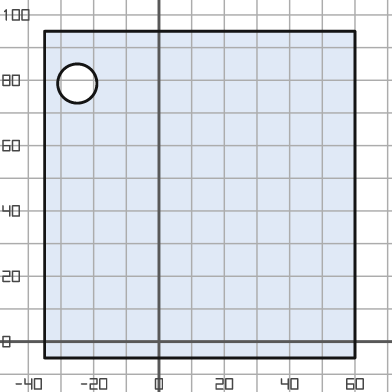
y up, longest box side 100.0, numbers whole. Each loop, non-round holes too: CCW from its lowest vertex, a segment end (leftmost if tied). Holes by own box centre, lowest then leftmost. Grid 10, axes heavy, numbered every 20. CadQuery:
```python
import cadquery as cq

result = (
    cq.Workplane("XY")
    .moveTo(-35.0, -5.0)
    .lineTo(60.0, -5.0)
    .lineTo(60.0, 95.0)
    .lineTo(-35.0, 95.0)
    .close()
    .moveTo(-25.0, 79.0)
    .circle(6.0)
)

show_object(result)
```